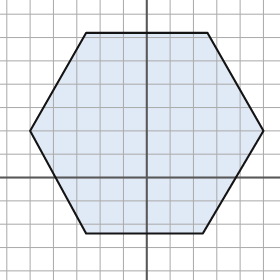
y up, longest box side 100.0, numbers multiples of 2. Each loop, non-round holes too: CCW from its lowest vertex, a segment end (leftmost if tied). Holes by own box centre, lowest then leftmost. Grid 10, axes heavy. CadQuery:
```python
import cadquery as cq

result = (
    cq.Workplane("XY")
    .moveTo(-26.0, -24.0)
    .lineTo(24.0, -24.0)
    .lineTo(50.0, 20.0)
    .lineTo(26.0, 62.0)
    .lineTo(-26.0, 62.0)
    .lineTo(-50.0, 20.0)
    .close()
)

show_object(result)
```